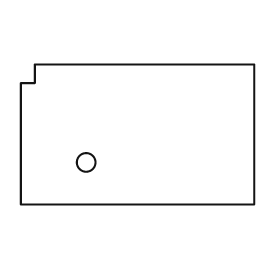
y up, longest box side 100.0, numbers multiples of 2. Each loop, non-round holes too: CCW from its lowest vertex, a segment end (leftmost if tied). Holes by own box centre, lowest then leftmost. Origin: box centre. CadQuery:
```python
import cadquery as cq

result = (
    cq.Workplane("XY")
    .moveTo(-50.0, -30.0)
    .lineTo(50.0, -30.0)
    .lineTo(50.0, 30.0)
    .lineTo(-44.0, 30.0)
    .lineTo(-44.0, 22.0)
    .lineTo(-50.0, 22.0)
    .close()
    .moveTo(-22.0, -12.0)
    .circle(4.0)
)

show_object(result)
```